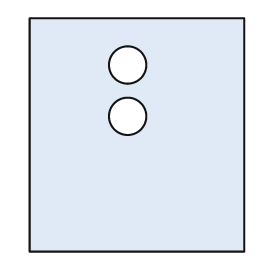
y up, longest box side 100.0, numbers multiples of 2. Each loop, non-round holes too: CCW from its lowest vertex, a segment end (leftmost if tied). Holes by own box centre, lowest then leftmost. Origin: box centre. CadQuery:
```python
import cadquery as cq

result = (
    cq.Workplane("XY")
    .moveTo(-46.0, -50.0)
    .lineTo(46.0, -50.0)
    .lineTo(46.0, 50.0)
    .lineTo(-46.0, 50.0)
    .close()
    .moveTo(-4.0, 8.0)
    .circle(8.0)
    .moveTo(-4.0, 30.0)
    .circle(8.0)
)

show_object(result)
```